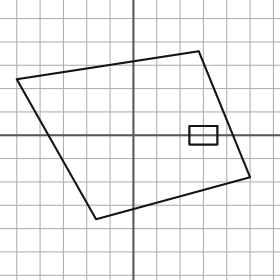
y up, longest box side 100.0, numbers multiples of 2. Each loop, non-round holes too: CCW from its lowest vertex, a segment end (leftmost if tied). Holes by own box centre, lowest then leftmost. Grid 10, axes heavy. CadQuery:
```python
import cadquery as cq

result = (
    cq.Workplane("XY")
    .moveTo(-16.0, -36.0)
    .lineTo(50.0, -18.0)
    .lineTo(28.0, 36.0)
    .lineTo(-50.0, 24.0)
    .close()
    .moveTo(24.0, -4.0)
    .lineTo(36.0, -4.0)
    .lineTo(36.0, 4.0)
    .lineTo(24.0, 4.0)
    .close()
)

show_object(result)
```